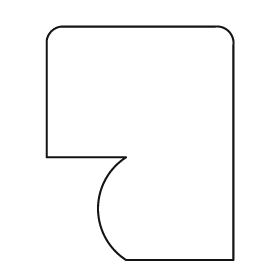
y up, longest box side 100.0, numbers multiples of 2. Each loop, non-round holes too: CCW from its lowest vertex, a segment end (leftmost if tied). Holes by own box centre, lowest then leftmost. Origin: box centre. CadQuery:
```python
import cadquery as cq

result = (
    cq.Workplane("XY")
    .moveTo(-6.0, -50.0)
    .lineTo(40.0, -50.0)
    .lineTo(40.0, 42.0)
    .threePointArc((38.0, 48.0), (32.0, 50.0))
    .lineTo(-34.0, 50.0)
    .threePointArc((-38.0, 48.0), (-40.0, 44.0))
    .lineTo(-40.0, -6.0)
    .lineTo(-6.0, -6.0)
    .threePointArc((-18.0, -28.0), (-6.0, -50.0))
    .close()
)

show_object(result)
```